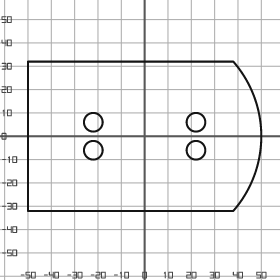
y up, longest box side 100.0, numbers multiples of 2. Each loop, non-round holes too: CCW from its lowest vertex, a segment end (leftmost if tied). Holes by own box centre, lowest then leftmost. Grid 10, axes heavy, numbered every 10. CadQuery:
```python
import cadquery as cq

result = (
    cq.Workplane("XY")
    .moveTo(-50.0, -32.0)
    .lineTo(38.0, -32.0)
    .threePointArc((50.0, 0.0), (38.0, 32.0))
    .lineTo(-50.0, 32.0)
    .close()
    .moveTo(-22.0, -6.0)
    .circle(4.0)
    .moveTo(22.0, -6.0)
    .circle(4.0)
    .moveTo(-22.0, 6.0)
    .circle(4.0)
    .moveTo(22.0, 6.0)
    .circle(4.0)
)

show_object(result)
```